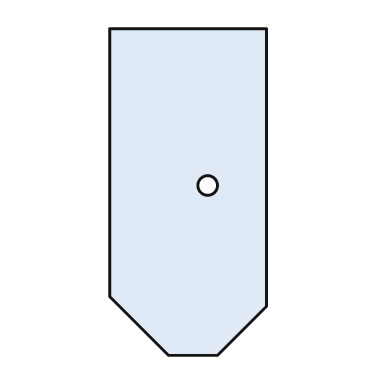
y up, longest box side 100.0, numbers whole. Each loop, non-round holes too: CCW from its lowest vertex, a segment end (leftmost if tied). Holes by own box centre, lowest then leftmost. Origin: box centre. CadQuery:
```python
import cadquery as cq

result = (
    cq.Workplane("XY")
    .moveTo(-6.0, -50.0)
    .lineTo(9.0, -50.0)
    .lineTo(24.0, -35.0)
    .lineTo(24.0, 50.0)
    .lineTo(-24.0, 50.0)
    .lineTo(-24.0, -32.0)
    .close()
    .moveTo(6.0, 2.0)
    .circle(3.0)
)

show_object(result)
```